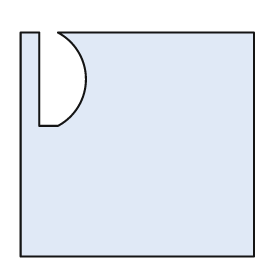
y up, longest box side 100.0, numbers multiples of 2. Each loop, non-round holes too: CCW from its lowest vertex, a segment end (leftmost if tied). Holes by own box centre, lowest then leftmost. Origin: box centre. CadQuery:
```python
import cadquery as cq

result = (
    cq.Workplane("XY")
    .moveTo(-50.0, -48.0)
    .lineTo(50.0, -48.0)
    .lineTo(50.0, 48.0)
    .lineTo(-34.0, 48.0)
    .threePointArc((-22.0, 28.0), (-34.0, 8.0))
    .lineTo(-42.0, 8.0)
    .lineTo(-42.0, 48.0)
    .lineTo(-50.0, 48.0)
    .close()
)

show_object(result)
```